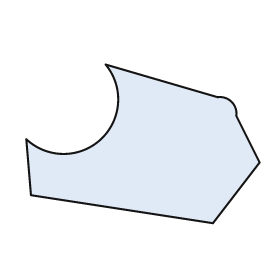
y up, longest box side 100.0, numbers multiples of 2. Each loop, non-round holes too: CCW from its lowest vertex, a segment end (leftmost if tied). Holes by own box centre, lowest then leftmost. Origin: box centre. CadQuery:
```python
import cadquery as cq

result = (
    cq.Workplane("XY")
    .moveTo(30.0, -34.0)
    .lineTo(50.0, -8.0)
    .lineTo(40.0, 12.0)
    .threePointArc((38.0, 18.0), (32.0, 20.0))
    .lineTo(-16.0, 34.0)
    .threePointArc((-18.0, 2.0), (-50.0, 2.0))
    .lineTo(-48.0, -22.0)
    .close()
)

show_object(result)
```